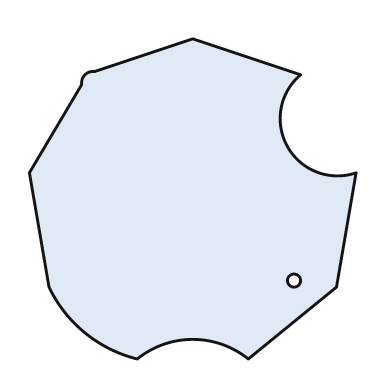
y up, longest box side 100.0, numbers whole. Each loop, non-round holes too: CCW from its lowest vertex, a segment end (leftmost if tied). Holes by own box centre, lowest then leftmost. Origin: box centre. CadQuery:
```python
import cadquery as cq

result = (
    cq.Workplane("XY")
    .moveTo(-17.0, -49.0)
    .threePointArc((0.0, -43.0), (17.0, -49.0))
    .lineTo(44.0, -27.0)
    .lineTo(50.0, 8.0)
    .threePointArc((29.0, 16.0), (33.0, 38.0))
    .lineTo(0.0, 49.0)
    .lineTo(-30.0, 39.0)
    .threePointArc((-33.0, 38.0), (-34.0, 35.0))
    .lineTo(-50.0, 8.0)
    .lineTo(-44.0, -27.0)
    .threePointArc((-33.0, -41.0), (-17.0, -49.0))
    .close()
    .moveTo(31.0, -25.0)
    .circle(2.0)
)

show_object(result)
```